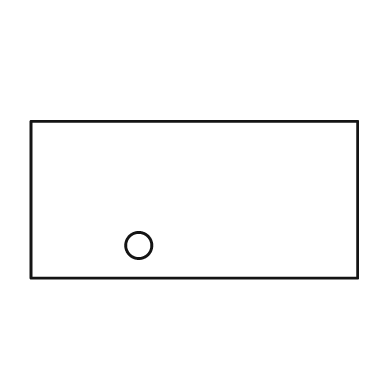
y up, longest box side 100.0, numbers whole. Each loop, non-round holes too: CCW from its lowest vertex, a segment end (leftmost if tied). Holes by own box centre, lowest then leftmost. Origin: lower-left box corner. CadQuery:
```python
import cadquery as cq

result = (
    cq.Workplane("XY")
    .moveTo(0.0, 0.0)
    .lineTo(100.0, 0.0)
    .lineTo(100.0, 48.0)
    .lineTo(0.0, 48.0)
    .close()
    .moveTo(33.0, 10.0)
    .circle(4.0)
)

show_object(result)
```